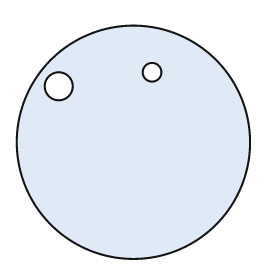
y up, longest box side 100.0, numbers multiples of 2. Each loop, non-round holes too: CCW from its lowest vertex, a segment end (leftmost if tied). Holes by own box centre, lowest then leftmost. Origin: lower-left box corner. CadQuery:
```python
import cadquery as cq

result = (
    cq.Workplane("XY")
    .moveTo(50.0, 50.0)
    .circle(50.0)
    .moveTo(18.0, 74.0)
    .circle(6.0)
    .moveTo(58.0, 80.0)
    .circle(4.0)
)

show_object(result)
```